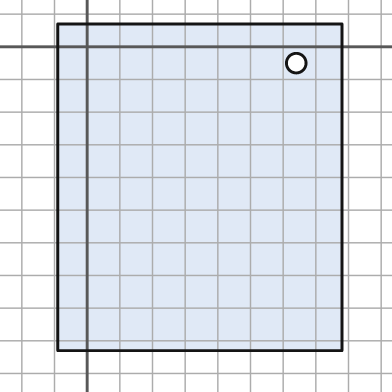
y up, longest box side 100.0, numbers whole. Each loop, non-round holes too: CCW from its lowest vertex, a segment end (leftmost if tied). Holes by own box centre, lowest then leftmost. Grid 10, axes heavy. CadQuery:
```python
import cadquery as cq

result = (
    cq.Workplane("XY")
    .moveTo(-9.0, -93.0)
    .lineTo(78.0, -93.0)
    .lineTo(78.0, 7.0)
    .lineTo(-9.0, 7.0)
    .close()
    .moveTo(64.0, -5.0)
    .circle(3.0)
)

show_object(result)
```